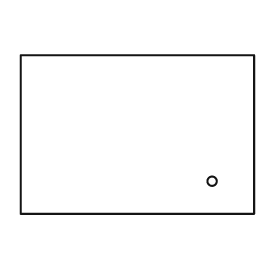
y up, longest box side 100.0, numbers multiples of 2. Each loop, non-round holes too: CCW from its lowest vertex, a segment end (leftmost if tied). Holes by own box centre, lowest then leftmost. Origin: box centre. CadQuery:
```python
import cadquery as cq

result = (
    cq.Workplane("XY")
    .moveTo(-50.0, -34.0)
    .lineTo(50.0, -34.0)
    .lineTo(50.0, 34.0)
    .lineTo(-50.0, 34.0)
    .close()
    .moveTo(32.0, -20.0)
    .circle(2.0)
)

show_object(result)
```